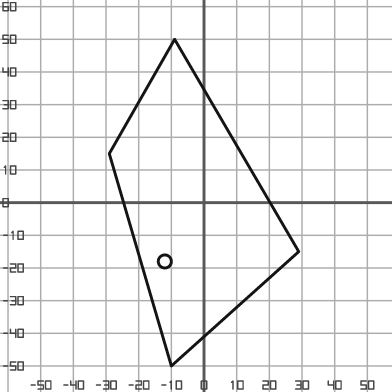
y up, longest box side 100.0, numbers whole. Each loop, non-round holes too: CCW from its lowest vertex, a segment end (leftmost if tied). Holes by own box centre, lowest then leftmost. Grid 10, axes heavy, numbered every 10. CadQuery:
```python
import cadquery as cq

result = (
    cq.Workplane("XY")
    .moveTo(-10.0, -50.0)
    .lineTo(29.0, -15.0)
    .lineTo(-9.0, 50.0)
    .lineTo(-29.0, 15.0)
    .close()
    .moveTo(-12.0, -18.0)
    .circle(2.0)
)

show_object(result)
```